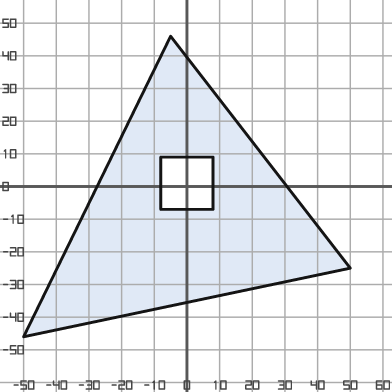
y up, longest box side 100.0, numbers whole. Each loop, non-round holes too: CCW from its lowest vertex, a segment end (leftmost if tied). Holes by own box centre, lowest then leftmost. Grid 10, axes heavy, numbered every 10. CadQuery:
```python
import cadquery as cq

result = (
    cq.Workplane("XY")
    .moveTo(-50.0, -46.0)
    .lineTo(50.0, -25.0)
    .lineTo(-5.0, 46.0)
    .close()
    .moveTo(-8.0, -7.0)
    .lineTo(8.0, -7.0)
    .lineTo(8.0, 9.0)
    .lineTo(-8.0, 9.0)
    .close()
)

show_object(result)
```